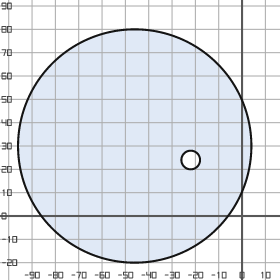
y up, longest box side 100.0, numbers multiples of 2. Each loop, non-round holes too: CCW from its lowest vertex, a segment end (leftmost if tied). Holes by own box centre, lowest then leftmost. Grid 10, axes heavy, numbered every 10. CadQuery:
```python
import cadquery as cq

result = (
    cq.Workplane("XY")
    .moveTo(-46.0, 30.0)
    .circle(50.0)
    .moveTo(-22.0, 24.0)
    .circle(4.0)
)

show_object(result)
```